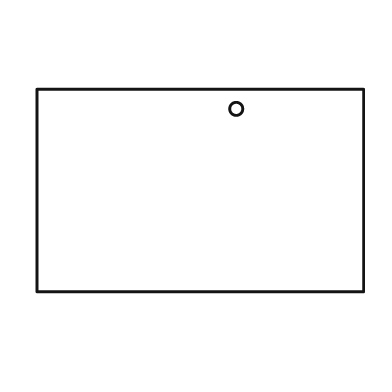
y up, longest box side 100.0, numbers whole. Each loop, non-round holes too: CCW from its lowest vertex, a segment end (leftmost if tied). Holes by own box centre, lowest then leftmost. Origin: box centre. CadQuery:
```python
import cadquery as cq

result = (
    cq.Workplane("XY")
    .moveTo(-50.0, -31.0)
    .lineTo(50.0, -31.0)
    .lineTo(50.0, 31.0)
    .lineTo(-50.0, 31.0)
    .close()
    .moveTo(11.0, 25.0)
    .circle(2.0)
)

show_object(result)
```